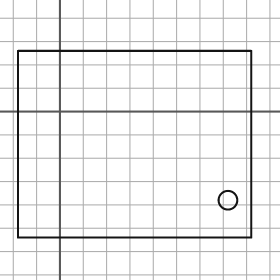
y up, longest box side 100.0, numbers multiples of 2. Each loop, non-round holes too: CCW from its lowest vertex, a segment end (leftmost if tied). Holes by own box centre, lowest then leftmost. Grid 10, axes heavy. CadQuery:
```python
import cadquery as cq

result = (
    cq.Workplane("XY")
    .moveTo(-18.0, -54.0)
    .lineTo(82.0, -54.0)
    .lineTo(82.0, 26.0)
    .lineTo(-18.0, 26.0)
    .close()
    .moveTo(72.0, -38.0)
    .circle(4.0)
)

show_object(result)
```